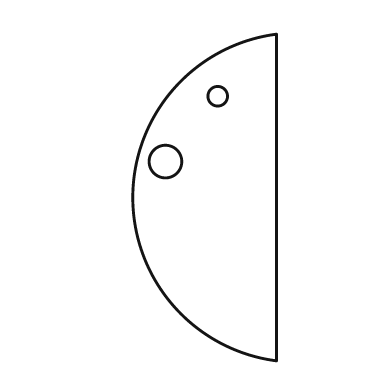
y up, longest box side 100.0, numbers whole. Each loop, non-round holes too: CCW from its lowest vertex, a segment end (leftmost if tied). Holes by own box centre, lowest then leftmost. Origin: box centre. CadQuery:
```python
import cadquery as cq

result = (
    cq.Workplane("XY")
    .moveTo(22.0, -50.0)
    .lineTo(22.0, 50.0)
    .threePointArc((-22.0, 0.0), (22.0, -50.0))
    .close()
    .moveTo(-12.0, 11.0)
    .circle(5.0)
    .moveTo(4.0, 31.0)
    .circle(3.0)
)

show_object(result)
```